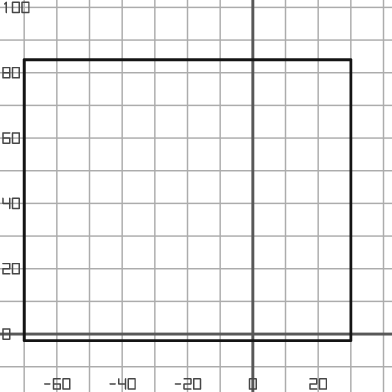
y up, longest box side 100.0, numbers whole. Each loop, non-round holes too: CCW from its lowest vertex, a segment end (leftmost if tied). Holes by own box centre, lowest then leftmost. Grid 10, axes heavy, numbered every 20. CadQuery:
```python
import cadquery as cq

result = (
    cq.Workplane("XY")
    .moveTo(-70.0, -2.0)
    .lineTo(30.0, -2.0)
    .lineTo(30.0, 84.0)
    .lineTo(-70.0, 84.0)
    .close()
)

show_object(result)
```